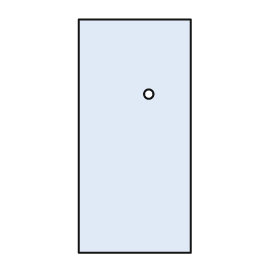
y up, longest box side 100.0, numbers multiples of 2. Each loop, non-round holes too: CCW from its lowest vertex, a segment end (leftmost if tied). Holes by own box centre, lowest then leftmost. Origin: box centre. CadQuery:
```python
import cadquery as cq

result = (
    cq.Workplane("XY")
    .moveTo(-24.0, -50.0)
    .lineTo(24.0, -50.0)
    .lineTo(24.0, 50.0)
    .lineTo(-24.0, 50.0)
    .close()
    .moveTo(6.0, 18.0)
    .circle(2.0)
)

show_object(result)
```